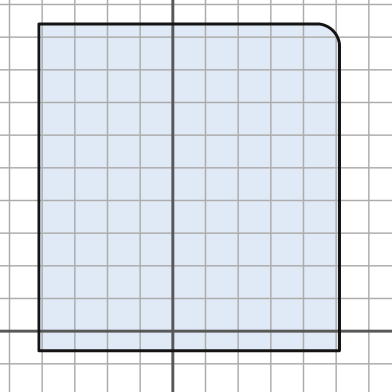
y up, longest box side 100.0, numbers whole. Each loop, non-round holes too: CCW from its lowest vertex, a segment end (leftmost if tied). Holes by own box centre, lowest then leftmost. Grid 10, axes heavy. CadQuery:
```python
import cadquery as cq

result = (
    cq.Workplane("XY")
    .moveTo(-41.0, -6.0)
    .lineTo(51.0, -6.0)
    .lineTo(51.0, 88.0)
    .threePointArc((49.0, 92.0), (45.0, 94.0))
    .lineTo(-41.0, 94.0)
    .close()
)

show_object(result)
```